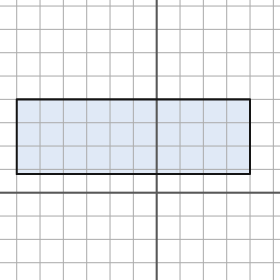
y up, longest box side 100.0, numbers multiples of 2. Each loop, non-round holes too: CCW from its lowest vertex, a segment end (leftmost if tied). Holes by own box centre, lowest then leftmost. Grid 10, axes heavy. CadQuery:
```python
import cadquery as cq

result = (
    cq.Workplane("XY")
    .moveTo(-60.0, 8.0)
    .lineTo(40.0, 8.0)
    .lineTo(40.0, 40.0)
    .lineTo(-60.0, 40.0)
    .close()
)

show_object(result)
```